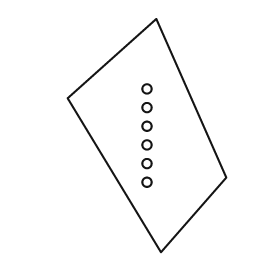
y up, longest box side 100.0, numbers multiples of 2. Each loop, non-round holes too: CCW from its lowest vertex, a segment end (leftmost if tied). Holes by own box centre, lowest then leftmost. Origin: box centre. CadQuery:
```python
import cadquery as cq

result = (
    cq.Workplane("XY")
    .moveTo(6.0, -50.0)
    .lineTo(34.0, -18.0)
    .lineTo(4.0, 50.0)
    .lineTo(-34.0, 16.0)
    .close()
    .moveTo(0.0, -20.0)
    .circle(2.0)
    .moveTo(0.0, -12.0)
    .circle(2.0)
    .moveTo(0.0, -4.0)
    .circle(2.0)
    .moveTo(0.0, 4.0)
    .circle(2.0)
    .moveTo(0.0, 12.0)
    .circle(2.0)
    .moveTo(0.0, 20.0)
    .circle(2.0)
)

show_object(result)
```